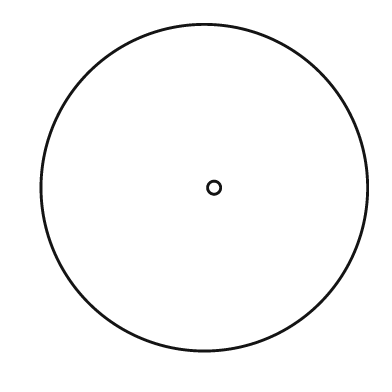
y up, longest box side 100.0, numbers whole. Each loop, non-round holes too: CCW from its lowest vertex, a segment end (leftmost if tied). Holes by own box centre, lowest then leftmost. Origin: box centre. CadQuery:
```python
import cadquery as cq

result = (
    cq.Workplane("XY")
    .moveTo(0.0, 0.0)
    .circle(50.0)
    .moveTo(3.0, 0.0)
    .circle(2.0)
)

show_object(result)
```